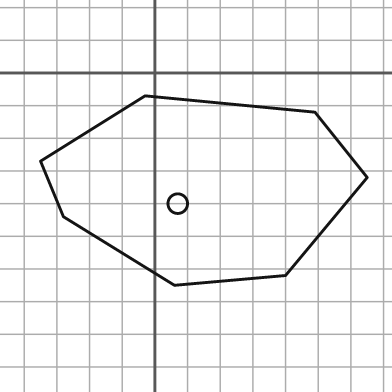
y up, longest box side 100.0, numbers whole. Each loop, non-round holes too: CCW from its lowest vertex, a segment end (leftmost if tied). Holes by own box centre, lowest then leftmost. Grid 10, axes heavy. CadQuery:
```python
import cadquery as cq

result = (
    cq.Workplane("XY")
    .moveTo(6.0, -65.0)
    .lineTo(40.0, -62.0)
    .lineTo(65.0, -32.0)
    .lineTo(49.0, -12.0)
    .lineTo(-3.0, -7.0)
    .lineTo(-35.0, -27.0)
    .lineTo(-28.0, -44.0)
    .close()
    .moveTo(7.0, -40.0)
    .circle(3.0)
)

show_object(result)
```